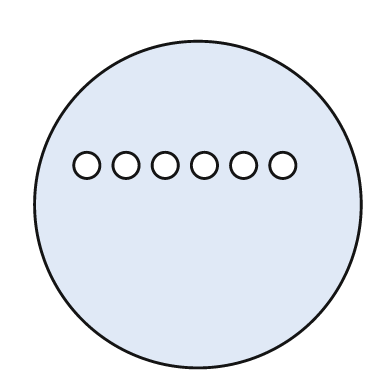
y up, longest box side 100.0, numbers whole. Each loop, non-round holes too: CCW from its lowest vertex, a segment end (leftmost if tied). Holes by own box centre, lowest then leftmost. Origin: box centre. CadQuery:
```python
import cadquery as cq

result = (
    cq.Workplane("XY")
    .moveTo(0.0, 0.0)
    .circle(50.0)
    .moveTo(-34.0, 12.0)
    .circle(4.0)
    .moveTo(-22.0, 12.0)
    .circle(4.0)
    .moveTo(-10.0, 12.0)
    .circle(4.0)
    .moveTo(2.0, 12.0)
    .circle(4.0)
    .moveTo(14.0, 12.0)
    .circle(4.0)
    .moveTo(26.0, 12.0)
    .circle(4.0)
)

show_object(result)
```